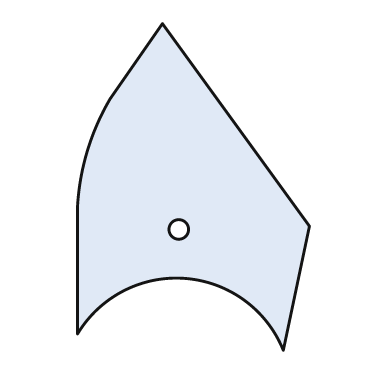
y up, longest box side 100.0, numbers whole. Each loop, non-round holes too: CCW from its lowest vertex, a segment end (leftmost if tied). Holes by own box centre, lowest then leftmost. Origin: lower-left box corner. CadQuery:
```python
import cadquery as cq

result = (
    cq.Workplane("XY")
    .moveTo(63.0, 0.0)
    .lineTo(71.0, 38.0)
    .lineTo(26.0, 100.0)
    .lineTo(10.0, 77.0)
    .threePointArc((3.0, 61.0), (0.0, 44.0))
    .lineTo(0.0, 5.0)
    .threePointArc((33.0, 22.0), (63.0, 0.0))
    .close()
    .moveTo(31.0, 37.0)
    .circle(3.0)
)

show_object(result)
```